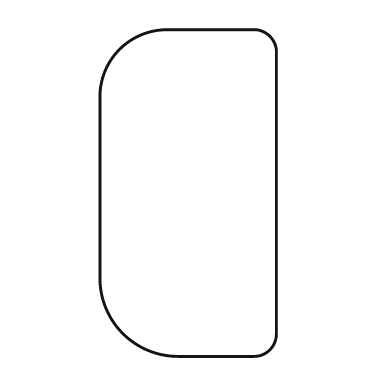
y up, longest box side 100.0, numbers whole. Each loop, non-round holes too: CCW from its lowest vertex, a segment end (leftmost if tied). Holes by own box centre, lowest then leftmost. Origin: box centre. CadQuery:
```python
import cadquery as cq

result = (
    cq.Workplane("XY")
    .moveTo(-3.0, -50.0)
    .lineTo(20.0, -50.0)
    .threePointArc((25.0, -48.0), (27.0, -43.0))
    .lineTo(27.0, 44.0)
    .threePointArc((25.0, 48.0), (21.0, 50.0))
    .lineTo(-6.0, 50.0)
    .threePointArc((-21.0, 44.0), (-27.0, 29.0))
    .lineTo(-27.0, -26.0)
    .threePointArc((-20.0, -43.0), (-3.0, -50.0))
    .close()
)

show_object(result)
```